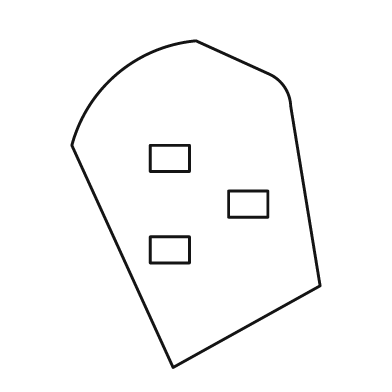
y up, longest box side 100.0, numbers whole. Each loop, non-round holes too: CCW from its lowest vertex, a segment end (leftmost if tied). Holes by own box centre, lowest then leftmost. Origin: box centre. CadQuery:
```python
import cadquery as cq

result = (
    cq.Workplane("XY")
    .moveTo(-7.0, -50.0)
    .lineTo(38.0, -25.0)
    .lineTo(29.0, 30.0)
    .threePointArc((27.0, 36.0), (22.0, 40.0))
    .lineTo(0.0, 50.0)
    .threePointArc((-24.0, 40.0), (-38.0, 18.0))
    .close()
    .moveTo(-14.0, -18.0)
    .lineTo(-2.0, -18.0)
    .lineTo(-2.0, -10.0)
    .lineTo(-14.0, -10.0)
    .close()
    .moveTo(10.0, -4.0)
    .lineTo(22.0, -4.0)
    .lineTo(22.0, 4.0)
    .lineTo(10.0, 4.0)
    .close()
    .moveTo(-14.0, 10.0)
    .lineTo(-2.0, 10.0)
    .lineTo(-2.0, 18.0)
    .lineTo(-14.0, 18.0)
    .close()
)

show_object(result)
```